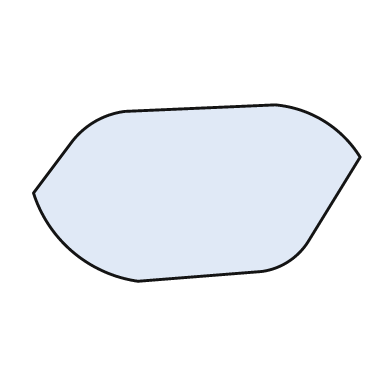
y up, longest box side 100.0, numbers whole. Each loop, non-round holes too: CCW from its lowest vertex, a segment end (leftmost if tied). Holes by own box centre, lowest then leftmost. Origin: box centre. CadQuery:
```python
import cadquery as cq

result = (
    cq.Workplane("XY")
    .moveTo(-18.0, -27.0)
    .lineTo(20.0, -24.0)
    .threePointArc((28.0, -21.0), (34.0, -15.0))
    .lineTo(50.0, 11.0)
    .threePointArc((39.0, 22.0), (24.0, 27.0))
    .lineTo(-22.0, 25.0)
    .threePointArc((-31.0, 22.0), (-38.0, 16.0))
    .lineTo(-50.0, 0.0)
    .threePointArc((-38.0, -18.0), (-18.0, -27.0))
    .close()
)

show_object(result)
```